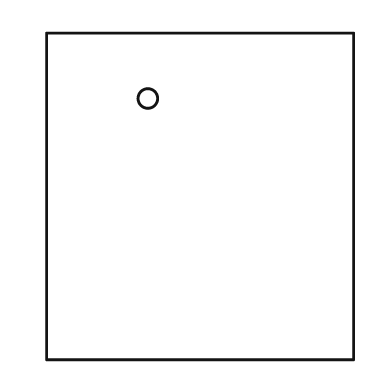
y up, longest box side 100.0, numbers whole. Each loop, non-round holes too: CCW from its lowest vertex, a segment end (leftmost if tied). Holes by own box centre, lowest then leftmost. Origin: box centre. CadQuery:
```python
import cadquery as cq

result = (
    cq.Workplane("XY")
    .moveTo(-47.0, -50.0)
    .lineTo(47.0, -50.0)
    .lineTo(47.0, 50.0)
    .lineTo(-47.0, 50.0)
    .close()
    .moveTo(-16.0, 30.0)
    .circle(3.0)
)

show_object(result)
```